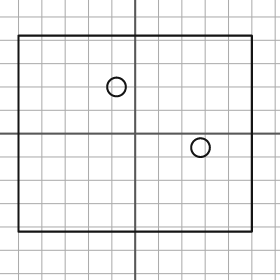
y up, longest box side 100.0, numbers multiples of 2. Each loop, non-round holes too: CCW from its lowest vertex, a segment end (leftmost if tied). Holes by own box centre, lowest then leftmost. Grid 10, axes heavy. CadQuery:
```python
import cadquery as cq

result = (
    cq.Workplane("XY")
    .moveTo(-50.0, -42.0)
    .lineTo(50.0, -42.0)
    .lineTo(50.0, 42.0)
    .lineTo(-50.0, 42.0)
    .close()
    .moveTo(28.0, -6.0)
    .circle(4.0)
    .moveTo(-8.0, 20.0)
    .circle(4.0)
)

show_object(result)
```